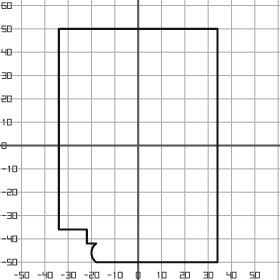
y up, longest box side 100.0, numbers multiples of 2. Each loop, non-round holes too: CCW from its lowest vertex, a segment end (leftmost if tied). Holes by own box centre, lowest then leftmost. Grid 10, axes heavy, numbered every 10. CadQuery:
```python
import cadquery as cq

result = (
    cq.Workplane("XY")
    .moveTo(-18.0, -50.0)
    .lineTo(34.0, -50.0)
    .lineTo(34.0, 50.0)
    .lineTo(-34.0, 50.0)
    .lineTo(-34.0, -36.0)
    .lineTo(-22.0, -36.0)
    .lineTo(-22.0, -42.0)
    .lineTo(-18.0, -42.0)
    .threePointArc((-20.0, -46.0), (-18.0, -50.0))
    .close()
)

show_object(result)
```